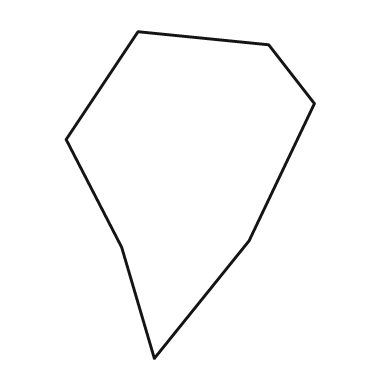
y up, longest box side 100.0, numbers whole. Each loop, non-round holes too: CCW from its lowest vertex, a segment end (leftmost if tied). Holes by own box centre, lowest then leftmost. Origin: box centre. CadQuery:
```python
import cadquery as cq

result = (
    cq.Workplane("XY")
    .moveTo(-11.0, -50.0)
    .lineTo(18.0, -14.0)
    .lineTo(38.0, 28.0)
    .lineTo(24.0, 46.0)
    .lineTo(-16.0, 50.0)
    .lineTo(-38.0, 17.0)
    .lineTo(-21.0, -16.0)
    .close()
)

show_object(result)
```